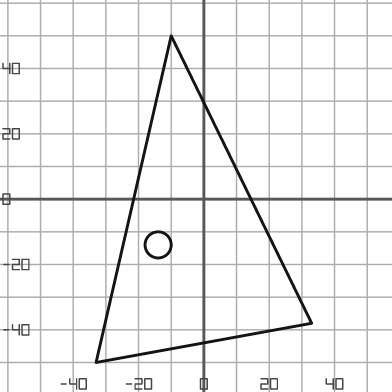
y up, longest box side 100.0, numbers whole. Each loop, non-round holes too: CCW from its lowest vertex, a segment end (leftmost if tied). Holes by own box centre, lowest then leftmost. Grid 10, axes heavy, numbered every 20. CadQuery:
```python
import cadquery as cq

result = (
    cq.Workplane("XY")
    .moveTo(-33.0, -50.0)
    .lineTo(33.0, -38.0)
    .lineTo(-10.0, 50.0)
    .close()
    .moveTo(-14.0, -14.0)
    .circle(4.0)
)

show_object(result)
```